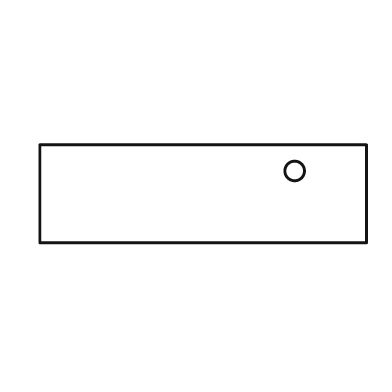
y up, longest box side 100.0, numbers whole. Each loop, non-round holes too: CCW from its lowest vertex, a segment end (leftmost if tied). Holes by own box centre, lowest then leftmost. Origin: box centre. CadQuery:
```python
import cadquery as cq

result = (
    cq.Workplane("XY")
    .moveTo(-50.0, -15.0)
    .lineTo(50.0, -15.0)
    .lineTo(50.0, 15.0)
    .lineTo(-50.0, 15.0)
    .close()
    .moveTo(28.0, 7.0)
    .circle(3.0)
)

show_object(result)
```